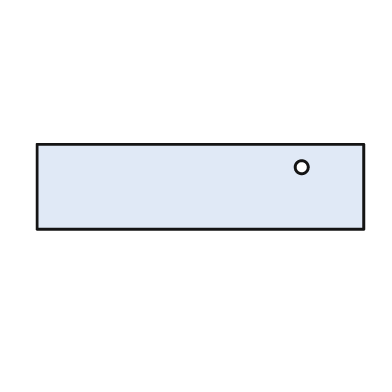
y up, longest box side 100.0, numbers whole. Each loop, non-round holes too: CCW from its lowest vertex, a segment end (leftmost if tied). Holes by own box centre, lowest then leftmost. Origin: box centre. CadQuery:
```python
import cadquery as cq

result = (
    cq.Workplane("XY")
    .moveTo(-50.0, -13.0)
    .lineTo(50.0, -13.0)
    .lineTo(50.0, 13.0)
    .lineTo(-50.0, 13.0)
    .close()
    .moveTo(31.0, 6.0)
    .circle(2.0)
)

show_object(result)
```